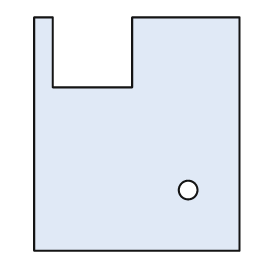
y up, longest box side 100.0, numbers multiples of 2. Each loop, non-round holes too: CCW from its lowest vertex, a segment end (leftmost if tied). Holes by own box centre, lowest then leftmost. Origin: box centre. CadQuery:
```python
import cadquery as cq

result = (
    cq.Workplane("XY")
    .moveTo(-44.0, -50.0)
    .lineTo(44.0, -50.0)
    .lineTo(44.0, 50.0)
    .lineTo(-2.0, 50.0)
    .lineTo(-2.0, 20.0)
    .lineTo(-36.0, 20.0)
    .lineTo(-36.0, 50.0)
    .lineTo(-44.0, 50.0)
    .close()
    .moveTo(22.0, -24.0)
    .circle(4.0)
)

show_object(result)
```